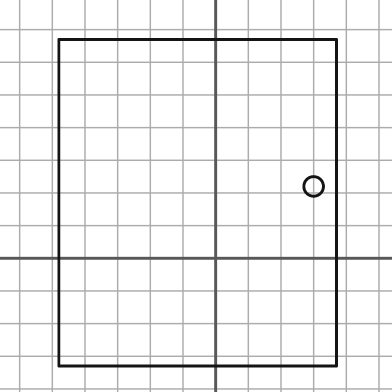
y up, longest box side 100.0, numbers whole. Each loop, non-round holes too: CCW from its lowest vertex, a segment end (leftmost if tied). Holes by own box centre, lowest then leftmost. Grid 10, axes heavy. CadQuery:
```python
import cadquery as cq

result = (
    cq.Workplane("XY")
    .moveTo(-48.0, -33.0)
    .lineTo(37.0, -33.0)
    .lineTo(37.0, 67.0)
    .lineTo(-48.0, 67.0)
    .close()
    .moveTo(30.0, 22.0)
    .circle(3.0)
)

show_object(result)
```